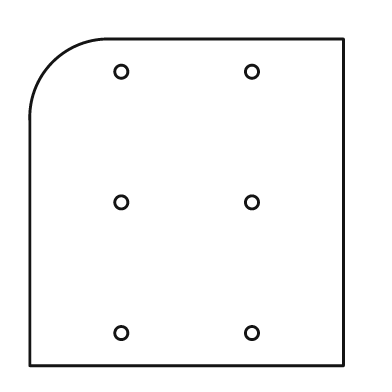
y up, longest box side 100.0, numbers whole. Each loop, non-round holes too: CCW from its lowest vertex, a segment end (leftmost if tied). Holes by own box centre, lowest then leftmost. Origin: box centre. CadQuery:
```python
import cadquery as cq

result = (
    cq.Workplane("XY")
    .moveTo(-48.0, -50.0)
    .lineTo(48.0, -50.0)
    .lineTo(48.0, 50.0)
    .lineTo(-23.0, 50.0)
    .threePointArc((-41.0, 43.0), (-48.0, 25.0))
    .close()
    .moveTo(-20.0, -40.0)
    .circle(2.0)
    .moveTo(20.0, -40.0)
    .circle(2.0)
    .moveTo(-20.0, 0.0)
    .circle(2.0)
    .moveTo(20.0, 0.0)
    .circle(2.0)
    .moveTo(-20.0, 40.0)
    .circle(2.0)
    .moveTo(20.0, 40.0)
    .circle(2.0)
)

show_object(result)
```